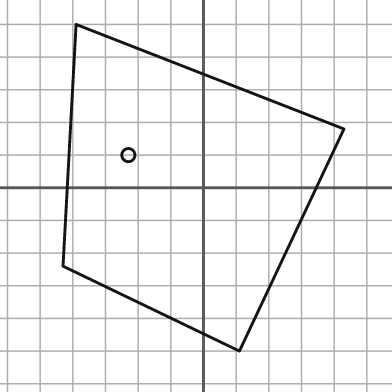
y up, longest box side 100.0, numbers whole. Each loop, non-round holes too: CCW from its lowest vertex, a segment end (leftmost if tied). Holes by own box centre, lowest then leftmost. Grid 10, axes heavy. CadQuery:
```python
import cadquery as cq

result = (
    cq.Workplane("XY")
    .moveTo(11.0, -50.0)
    .lineTo(43.0, 18.0)
    .lineTo(-39.0, 50.0)
    .lineTo(-43.0, -24.0)
    .close()
    .moveTo(-23.0, 10.0)
    .circle(2.0)
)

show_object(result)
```